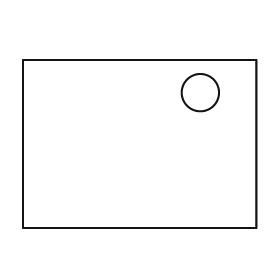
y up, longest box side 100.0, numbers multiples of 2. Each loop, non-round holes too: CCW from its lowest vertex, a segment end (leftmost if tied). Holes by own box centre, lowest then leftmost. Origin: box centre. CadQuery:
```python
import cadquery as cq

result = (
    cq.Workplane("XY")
    .moveTo(-50.0, -36.0)
    .lineTo(50.0, -36.0)
    .lineTo(50.0, 36.0)
    .lineTo(-50.0, 36.0)
    .close()
    .moveTo(26.0, 22.0)
    .circle(8.0)
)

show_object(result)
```